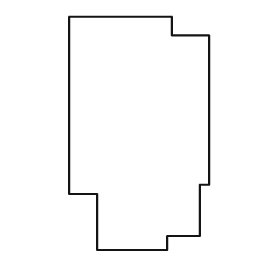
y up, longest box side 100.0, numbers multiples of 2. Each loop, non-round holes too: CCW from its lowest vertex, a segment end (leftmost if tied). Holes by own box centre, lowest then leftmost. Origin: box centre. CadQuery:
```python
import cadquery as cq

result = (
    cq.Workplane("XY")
    .moveTo(-18.0, -50.0)
    .lineTo(12.0, -50.0)
    .lineTo(12.0, -44.0)
    .lineTo(26.0, -44.0)
    .lineTo(26.0, -22.0)
    .lineTo(30.0, -22.0)
    .lineTo(30.0, 42.0)
    .lineTo(14.0, 42.0)
    .lineTo(14.0, 50.0)
    .lineTo(-30.0, 50.0)
    .lineTo(-30.0, -26.0)
    .lineTo(-18.0, -26.0)
    .close()
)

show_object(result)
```